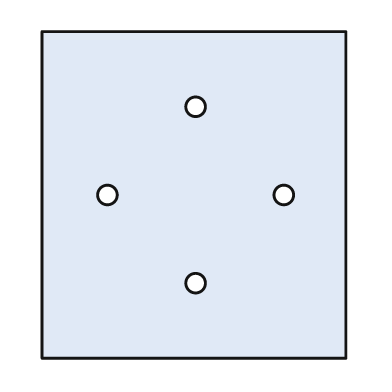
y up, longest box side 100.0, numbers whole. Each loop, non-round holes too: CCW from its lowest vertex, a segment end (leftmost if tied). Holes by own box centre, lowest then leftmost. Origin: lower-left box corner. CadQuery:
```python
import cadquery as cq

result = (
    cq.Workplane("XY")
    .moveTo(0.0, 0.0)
    .lineTo(93.0, 0.0)
    .lineTo(93.0, 100.0)
    .lineTo(0.0, 100.0)
    .close()
    .moveTo(47.0, 23.0)
    .circle(3.0)
    .moveTo(20.0, 50.0)
    .circle(3.0)
    .moveTo(74.0, 50.0)
    .circle(3.0)
    .moveTo(47.0, 77.0)
    .circle(3.0)
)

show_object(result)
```